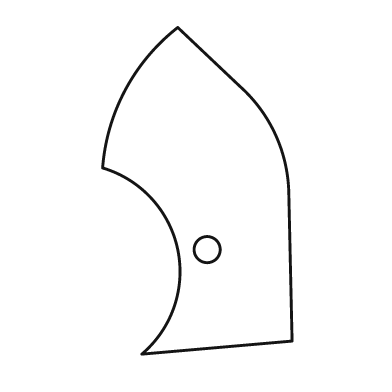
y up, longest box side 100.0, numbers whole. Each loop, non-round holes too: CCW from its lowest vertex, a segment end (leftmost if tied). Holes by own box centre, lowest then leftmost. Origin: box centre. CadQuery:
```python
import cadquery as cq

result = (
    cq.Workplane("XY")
    .moveTo(-17.0, -50.0)
    .lineTo(29.0, -46.0)
    .lineTo(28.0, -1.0)
    .threePointArc((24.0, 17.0), (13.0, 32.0))
    .lineTo(-6.0, 50.0)
    .threePointArc((-22.0, 31.0), (-29.0, 7.0))
    .threePointArc((-6.0, -18.0), (-17.0, -50.0))
    .close()
    .moveTo(3.0, -18.0)
    .circle(4.0)
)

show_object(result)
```